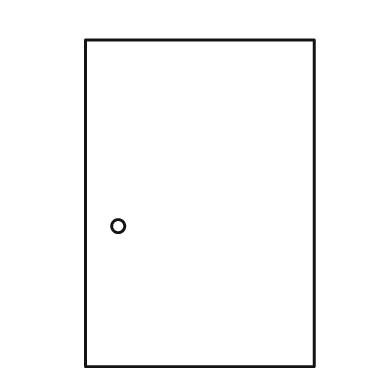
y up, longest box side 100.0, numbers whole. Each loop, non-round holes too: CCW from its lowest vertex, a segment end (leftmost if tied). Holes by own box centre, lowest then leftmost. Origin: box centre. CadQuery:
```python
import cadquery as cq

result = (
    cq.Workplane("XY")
    .moveTo(-35.0, -50.0)
    .lineTo(35.0, -50.0)
    .lineTo(35.0, 50.0)
    .lineTo(-35.0, 50.0)
    .close()
    .moveTo(-25.0, -7.0)
    .circle(2.0)
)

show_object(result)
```